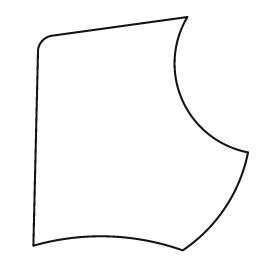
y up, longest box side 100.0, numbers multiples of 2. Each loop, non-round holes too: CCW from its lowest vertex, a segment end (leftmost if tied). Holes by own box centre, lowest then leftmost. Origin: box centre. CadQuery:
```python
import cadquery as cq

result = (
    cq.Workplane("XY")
    .moveTo(18.0, -50.0)
    .threePointArc((36.0, -32.0), (46.0, -8.0))
    .threePointArc((18.0, 14.0), (20.0, 50.0))
    .lineTo(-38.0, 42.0)
    .threePointArc((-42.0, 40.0), (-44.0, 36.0))
    .lineTo(-46.0, -48.0)
    .threePointArc((-14.0, -44.0), (18.0, -50.0))
    .close()
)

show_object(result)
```